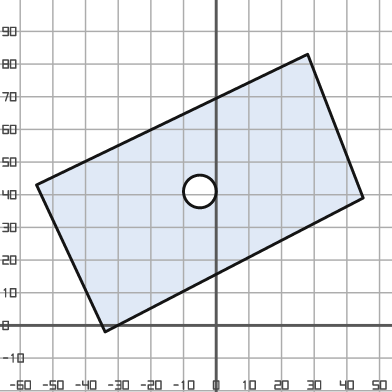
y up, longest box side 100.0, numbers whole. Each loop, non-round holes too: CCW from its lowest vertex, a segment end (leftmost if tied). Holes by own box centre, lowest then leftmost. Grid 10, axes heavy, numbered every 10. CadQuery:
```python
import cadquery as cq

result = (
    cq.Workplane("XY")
    .moveTo(-34.0, -2.0)
    .lineTo(45.0, 39.0)
    .lineTo(28.0, 83.0)
    .lineTo(-55.0, 43.0)
    .close()
    .moveTo(-5.0, 41.0)
    .circle(5.0)
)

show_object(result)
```